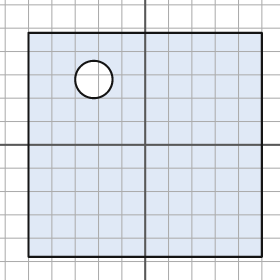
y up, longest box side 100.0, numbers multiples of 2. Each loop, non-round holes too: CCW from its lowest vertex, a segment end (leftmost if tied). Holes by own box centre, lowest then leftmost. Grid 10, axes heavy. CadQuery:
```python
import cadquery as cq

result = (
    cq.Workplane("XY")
    .moveTo(-50.0, -48.0)
    .lineTo(50.0, -48.0)
    .lineTo(50.0, 48.0)
    .lineTo(-50.0, 48.0)
    .close()
    .moveTo(-22.0, 28.0)
    .circle(8.0)
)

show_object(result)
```